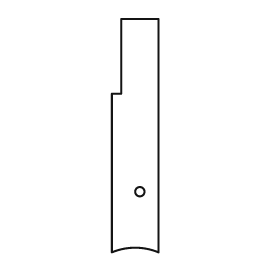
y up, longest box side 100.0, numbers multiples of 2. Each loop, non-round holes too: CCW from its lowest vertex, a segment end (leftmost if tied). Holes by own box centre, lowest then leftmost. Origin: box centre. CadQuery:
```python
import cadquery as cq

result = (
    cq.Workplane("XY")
    .moveTo(-10.0, -50.0)
    .threePointArc((0.0, -48.0), (10.0, -50.0))
    .lineTo(10.0, 50.0)
    .lineTo(-6.0, 50.0)
    .lineTo(-6.0, 18.0)
    .lineTo(-10.0, 18.0)
    .close()
    .moveTo(2.0, -24.0)
    .circle(2.0)
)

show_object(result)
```